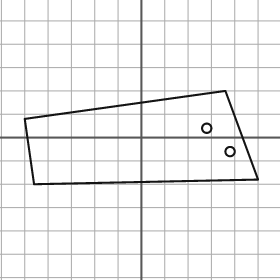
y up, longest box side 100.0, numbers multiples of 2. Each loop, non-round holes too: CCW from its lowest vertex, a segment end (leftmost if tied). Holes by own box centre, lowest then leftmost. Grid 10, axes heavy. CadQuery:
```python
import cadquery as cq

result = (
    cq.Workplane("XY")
    .moveTo(-46.0, -20.0)
    .lineTo(50.0, -18.0)
    .lineTo(36.0, 20.0)
    .lineTo(-50.0, 8.0)
    .close()
    .moveTo(38.0, -6.0)
    .circle(2.0)
    .moveTo(28.0, 4.0)
    .circle(2.0)
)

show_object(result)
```